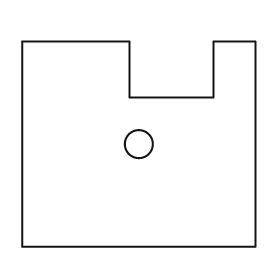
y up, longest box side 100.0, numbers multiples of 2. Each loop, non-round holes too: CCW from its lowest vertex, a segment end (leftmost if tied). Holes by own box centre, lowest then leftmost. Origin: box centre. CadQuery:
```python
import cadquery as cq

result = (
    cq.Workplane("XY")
    .moveTo(-50.0, -44.0)
    .lineTo(50.0, -44.0)
    .lineTo(50.0, 44.0)
    .lineTo(32.0, 44.0)
    .lineTo(32.0, 20.0)
    .lineTo(-4.0, 20.0)
    .lineTo(-4.0, 44.0)
    .lineTo(-50.0, 44.0)
    .close()
    .moveTo(0.0, 0.0)
    .circle(6.0)
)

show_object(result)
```